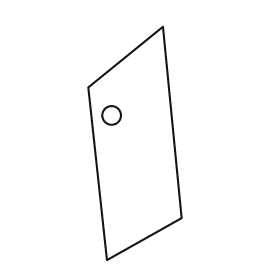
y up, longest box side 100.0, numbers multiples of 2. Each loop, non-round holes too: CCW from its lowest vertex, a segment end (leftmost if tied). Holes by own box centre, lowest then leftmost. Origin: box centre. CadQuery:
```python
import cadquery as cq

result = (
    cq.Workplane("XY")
    .moveTo(-12.0, -50.0)
    .lineTo(20.0, -32.0)
    .lineTo(12.0, 50.0)
    .lineTo(-20.0, 24.0)
    .close()
    .moveTo(-10.0, 12.0)
    .circle(4.0)
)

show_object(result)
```